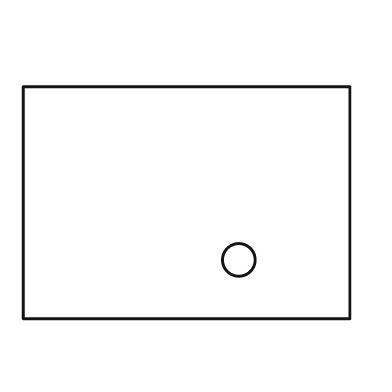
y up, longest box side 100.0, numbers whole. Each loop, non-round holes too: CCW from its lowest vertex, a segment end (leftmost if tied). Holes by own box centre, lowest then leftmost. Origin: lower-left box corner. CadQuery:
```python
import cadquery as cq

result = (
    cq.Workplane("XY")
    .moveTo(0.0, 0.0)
    .lineTo(100.0, 0.0)
    .lineTo(100.0, 71.0)
    .lineTo(0.0, 71.0)
    .close()
    .moveTo(66.0, 18.0)
    .circle(5.0)
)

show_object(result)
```